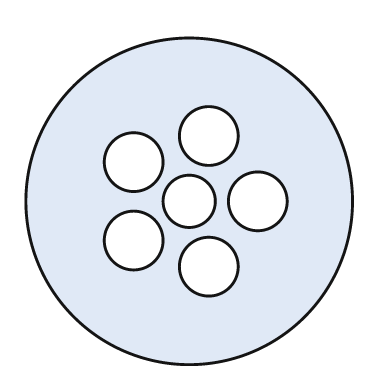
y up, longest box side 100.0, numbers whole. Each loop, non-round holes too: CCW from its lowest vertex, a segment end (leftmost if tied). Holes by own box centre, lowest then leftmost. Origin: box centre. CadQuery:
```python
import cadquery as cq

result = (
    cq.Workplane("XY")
    .moveTo(0.0, 0.0)
    .circle(50.0)
    .moveTo(6.0, -20.0)
    .circle(9.0)
    .moveTo(-17.0, -12.0)
    .circle(9.0)
    .moveTo(0.0, 0.0)
    .circle(8.0)
    .moveTo(21.0, 0.0)
    .circle(9.0)
    .moveTo(-17.0, 12.0)
    .circle(9.0)
    .moveTo(6.0, 20.0)
    .circle(9.0)
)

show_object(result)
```